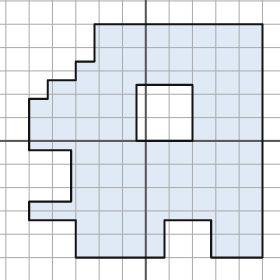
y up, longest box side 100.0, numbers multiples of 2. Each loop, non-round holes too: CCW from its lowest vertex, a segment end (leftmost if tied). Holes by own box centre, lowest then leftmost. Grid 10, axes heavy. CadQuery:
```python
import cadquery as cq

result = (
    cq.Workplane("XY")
    .moveTo(-30.0, -50.0)
    .lineTo(8.0, -50.0)
    .lineTo(8.0, -34.0)
    .lineTo(28.0, -34.0)
    .lineTo(28.0, -50.0)
    .lineTo(50.0, -50.0)
    .lineTo(50.0, 50.0)
    .lineTo(-22.0, 50.0)
    .lineTo(-22.0, 34.0)
    .lineTo(-30.0, 34.0)
    .lineTo(-30.0, 26.0)
    .lineTo(-42.0, 26.0)
    .lineTo(-42.0, 18.0)
    .lineTo(-50.0, 18.0)
    .lineTo(-50.0, -4.0)
    .lineTo(-32.0, -4.0)
    .lineTo(-32.0, -26.0)
    .lineTo(-50.0, -26.0)
    .lineTo(-50.0, -34.0)
    .lineTo(-30.0, -34.0)
    .close()
    .moveTo(-4.0, 0.0)
    .lineTo(20.0, 0.0)
    .lineTo(20.0, 24.0)
    .lineTo(-4.0, 24.0)
    .close()
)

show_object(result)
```